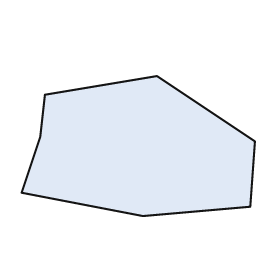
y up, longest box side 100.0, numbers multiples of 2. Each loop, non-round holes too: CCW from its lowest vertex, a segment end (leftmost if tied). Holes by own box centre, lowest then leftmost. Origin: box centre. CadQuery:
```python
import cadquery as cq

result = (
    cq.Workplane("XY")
    .moveTo(2.0, -30.0)
    .lineTo(48.0, -26.0)
    .lineTo(50.0, 2.0)
    .lineTo(8.0, 30.0)
    .lineTo(-40.0, 22.0)
    .lineTo(-42.0, 4.0)
    .lineTo(-50.0, -20.0)
    .close()
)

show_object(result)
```